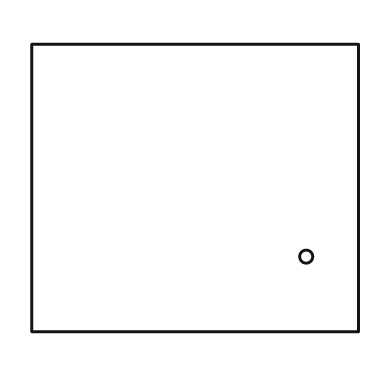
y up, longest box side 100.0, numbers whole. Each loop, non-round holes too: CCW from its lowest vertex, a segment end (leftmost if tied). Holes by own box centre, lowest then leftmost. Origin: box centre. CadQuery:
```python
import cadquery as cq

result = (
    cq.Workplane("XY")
    .moveTo(-50.0, -44.0)
    .lineTo(50.0, -44.0)
    .lineTo(50.0, 44.0)
    .lineTo(-50.0, 44.0)
    .close()
    .moveTo(34.0, -21.0)
    .circle(2.0)
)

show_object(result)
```